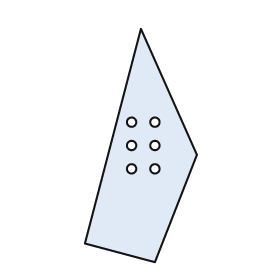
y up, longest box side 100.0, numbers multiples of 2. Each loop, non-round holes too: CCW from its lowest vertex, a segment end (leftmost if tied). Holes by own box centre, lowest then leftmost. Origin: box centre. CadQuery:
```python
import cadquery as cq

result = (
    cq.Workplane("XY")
    .moveTo(6.0, -50.0)
    .lineTo(24.0, -4.0)
    .lineTo(0.0, 50.0)
    .lineTo(-24.0, -42.0)
    .close()
    .moveTo(-4.0, -10.0)
    .circle(2.0)
    .moveTo(6.0, -10.0)
    .circle(2.0)
    .moveTo(-4.0, 0.0)
    .circle(2.0)
    .moveTo(6.0, 0.0)
    .circle(2.0)
    .moveTo(-4.0, 10.0)
    .circle(2.0)
    .moveTo(6.0, 10.0)
    .circle(2.0)
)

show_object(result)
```